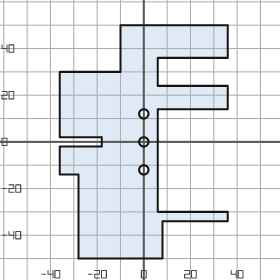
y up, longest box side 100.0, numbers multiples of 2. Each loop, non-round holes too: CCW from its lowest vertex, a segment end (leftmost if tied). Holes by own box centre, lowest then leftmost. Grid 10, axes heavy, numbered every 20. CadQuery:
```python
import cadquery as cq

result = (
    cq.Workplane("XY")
    .moveTo(-28.0, -50.0)
    .lineTo(8.0, -50.0)
    .lineTo(8.0, -34.0)
    .lineTo(36.0, -34.0)
    .lineTo(36.0, -30.0)
    .lineTo(6.0, -30.0)
    .lineTo(6.0, 14.0)
    .lineTo(36.0, 14.0)
    .lineTo(36.0, 24.0)
    .lineTo(6.0, 24.0)
    .lineTo(6.0, 36.0)
    .lineTo(36.0, 36.0)
    .lineTo(36.0, 50.0)
    .lineTo(-10.0, 50.0)
    .lineTo(-10.0, 30.0)
    .lineTo(-36.0, 30.0)
    .lineTo(-36.0, 2.0)
    .lineTo(-18.0, 2.0)
    .lineTo(-18.0, -2.0)
    .lineTo(-36.0, -2.0)
    .lineTo(-36.0, -14.0)
    .lineTo(-28.0, -14.0)
    .close()
    .moveTo(0.0, -12.0)
    .circle(2.0)
    .moveTo(0.0, 0.0)
    .circle(2.0)
    .moveTo(0.0, 12.0)
    .circle(2.0)
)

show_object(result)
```